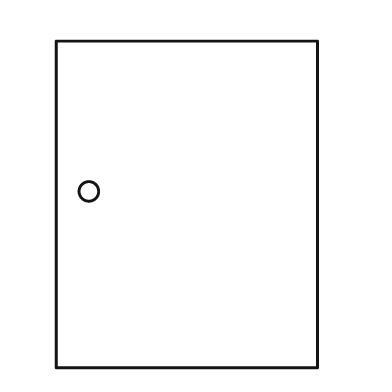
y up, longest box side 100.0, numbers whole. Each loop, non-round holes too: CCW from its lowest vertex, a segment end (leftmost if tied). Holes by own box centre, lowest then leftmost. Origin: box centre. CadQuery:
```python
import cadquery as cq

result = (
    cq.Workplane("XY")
    .moveTo(-40.0, -50.0)
    .lineTo(40.0, -50.0)
    .lineTo(40.0, 50.0)
    .lineTo(-40.0, 50.0)
    .close()
    .moveTo(-30.0, 4.0)
    .circle(3.0)
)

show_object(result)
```